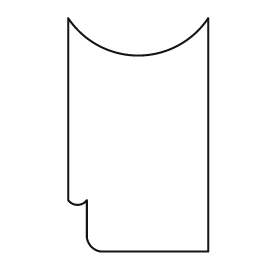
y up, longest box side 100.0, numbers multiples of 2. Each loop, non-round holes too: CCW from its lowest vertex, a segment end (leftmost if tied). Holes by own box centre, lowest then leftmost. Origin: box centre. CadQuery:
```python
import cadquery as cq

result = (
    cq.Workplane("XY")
    .moveTo(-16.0, -50.0)
    .lineTo(30.0, -50.0)
    .lineTo(30.0, 50.0)
    .threePointArc((0.0, 34.0), (-30.0, 50.0))
    .lineTo(-30.0, -28.0)
    .threePointArc((-26.0, -30.0), (-22.0, -28.0))
    .lineTo(-22.0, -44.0)
    .threePointArc((-20.0, -48.0), (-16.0, -50.0))
    .close()
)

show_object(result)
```